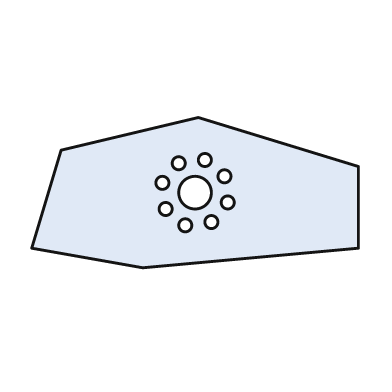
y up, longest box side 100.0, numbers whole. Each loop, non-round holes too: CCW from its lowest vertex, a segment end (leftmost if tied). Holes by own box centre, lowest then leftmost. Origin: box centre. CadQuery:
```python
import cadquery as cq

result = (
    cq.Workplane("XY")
    .moveTo(-16.0, -23.0)
    .lineTo(50.0, -17.0)
    .lineTo(50.0, 8.0)
    .lineTo(1.0, 23.0)
    .lineTo(-41.0, 13.0)
    .lineTo(-50.0, -17.0)
    .close()
    .moveTo(-3.0, -10.0)
    .circle(2.0)
    .moveTo(5.0, -9.0)
    .circle(2.0)
    .moveTo(-9.0, -5.0)
    .circle(2.0)
    .moveTo(10.0, -3.0)
    .circle(2.0)
    .moveTo(0.0, 0.0)
    .circle(5.0)
    .moveTo(-10.0, 3.0)
    .circle(2.0)
    .moveTo(9.0, 5.0)
    .circle(2.0)
    .moveTo(-5.0, 9.0)
    .circle(2.0)
    .moveTo(3.0, 10.0)
    .circle(2.0)
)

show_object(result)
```